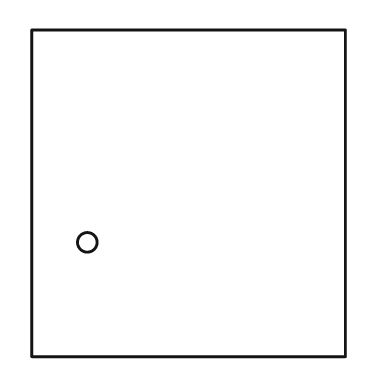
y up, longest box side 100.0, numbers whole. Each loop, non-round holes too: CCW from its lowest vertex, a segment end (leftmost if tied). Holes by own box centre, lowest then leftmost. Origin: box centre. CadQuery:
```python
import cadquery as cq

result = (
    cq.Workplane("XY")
    .moveTo(-48.0, -50.0)
    .lineTo(48.0, -50.0)
    .lineTo(48.0, 50.0)
    .lineTo(-48.0, 50.0)
    .close()
    .moveTo(-31.0, -15.0)
    .circle(3.0)
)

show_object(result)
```